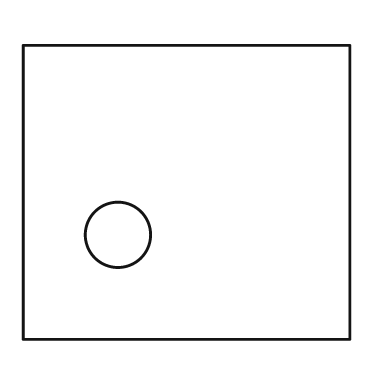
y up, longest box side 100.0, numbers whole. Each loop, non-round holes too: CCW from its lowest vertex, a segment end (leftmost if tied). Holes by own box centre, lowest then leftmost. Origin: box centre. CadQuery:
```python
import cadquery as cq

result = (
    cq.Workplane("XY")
    .moveTo(-50.0, -45.0)
    .lineTo(50.0, -45.0)
    .lineTo(50.0, 45.0)
    .lineTo(-50.0, 45.0)
    .close()
    .moveTo(-21.0, -13.0)
    .circle(10.0)
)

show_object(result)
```